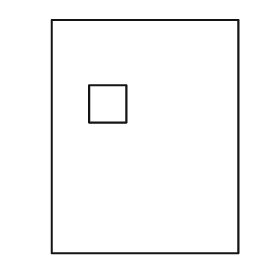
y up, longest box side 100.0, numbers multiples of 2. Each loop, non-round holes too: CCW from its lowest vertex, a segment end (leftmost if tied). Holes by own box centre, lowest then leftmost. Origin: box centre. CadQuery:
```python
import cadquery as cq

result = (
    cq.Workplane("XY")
    .moveTo(-40.0, -50.0)
    .lineTo(40.0, -50.0)
    .lineTo(40.0, 50.0)
    .lineTo(-40.0, 50.0)
    .close()
    .moveTo(-24.0, 6.0)
    .lineTo(-8.0, 6.0)
    .lineTo(-8.0, 22.0)
    .lineTo(-24.0, 22.0)
    .close()
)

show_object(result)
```